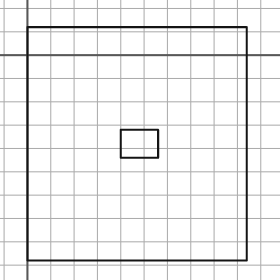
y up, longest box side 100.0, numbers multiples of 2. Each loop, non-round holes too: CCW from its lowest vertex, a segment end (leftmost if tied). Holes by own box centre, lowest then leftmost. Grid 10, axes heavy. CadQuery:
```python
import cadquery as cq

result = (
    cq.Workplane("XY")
    .moveTo(0.0, -88.0)
    .lineTo(94.0, -88.0)
    .lineTo(94.0, 12.0)
    .lineTo(0.0, 12.0)
    .close()
    .moveTo(40.0, -44.0)
    .lineTo(56.0, -44.0)
    .lineTo(56.0, -32.0)
    .lineTo(40.0, -32.0)
    .close()
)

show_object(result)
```